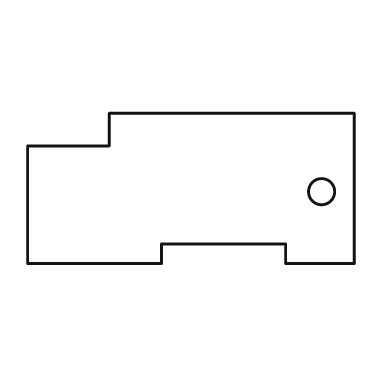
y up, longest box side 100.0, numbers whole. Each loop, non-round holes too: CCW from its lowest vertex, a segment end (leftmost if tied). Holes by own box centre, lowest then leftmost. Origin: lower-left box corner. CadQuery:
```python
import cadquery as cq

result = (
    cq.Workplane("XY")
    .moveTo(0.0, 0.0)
    .lineTo(41.0, 0.0)
    .lineTo(41.0, 6.0)
    .lineTo(79.0, 6.0)
    .lineTo(79.0, 0.0)
    .lineTo(100.0, 0.0)
    .lineTo(100.0, 46.0)
    .lineTo(25.0, 46.0)
    .lineTo(25.0, 36.0)
    .lineTo(0.0, 36.0)
    .close()
    .moveTo(90.0, 22.0)
    .circle(4.0)
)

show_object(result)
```